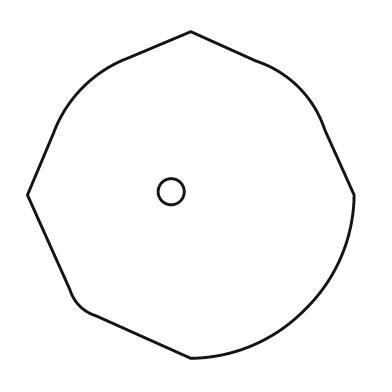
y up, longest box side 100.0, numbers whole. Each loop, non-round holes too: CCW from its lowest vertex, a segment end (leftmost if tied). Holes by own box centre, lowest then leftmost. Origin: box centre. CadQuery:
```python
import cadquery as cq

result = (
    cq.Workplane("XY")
    .moveTo(0.0, -50.0)
    .threePointArc((19.0, -46.0), (35.0, -35.0))
    .threePointArc((46.0, -19.0), (50.0, 0.0))
    .lineTo(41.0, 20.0)
    .threePointArc((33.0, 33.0), (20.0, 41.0))
    .lineTo(0.0, 50.0)
    .lineTo(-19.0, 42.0)
    .threePointArc((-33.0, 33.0), (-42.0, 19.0))
    .lineTo(-50.0, 0.0)
    .lineTo(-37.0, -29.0)
    .threePointArc((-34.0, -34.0), (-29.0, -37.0))
    .close()
    .moveTo(-6.0, 1.0)
    .circle(4.0)
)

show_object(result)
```